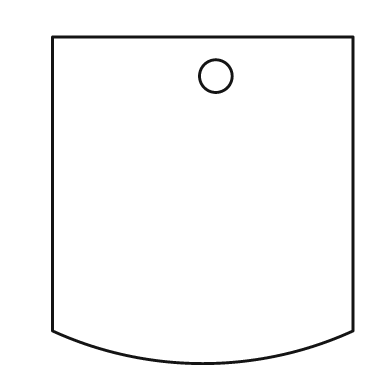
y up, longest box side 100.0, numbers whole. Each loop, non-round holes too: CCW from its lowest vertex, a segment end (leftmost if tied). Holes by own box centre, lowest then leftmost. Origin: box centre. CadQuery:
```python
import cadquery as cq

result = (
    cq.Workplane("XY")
    .moveTo(-46.0, -40.0)
    .threePointArc((0.0, -50.0), (46.0, -40.0))
    .lineTo(46.0, 50.0)
    .lineTo(-46.0, 50.0)
    .close()
    .moveTo(4.0, 38.0)
    .circle(5.0)
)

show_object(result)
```